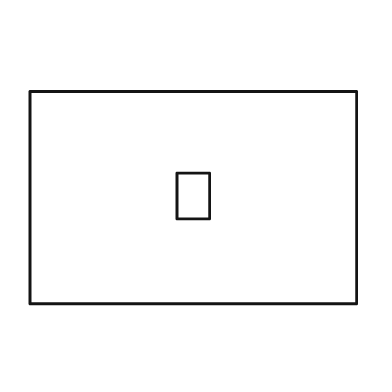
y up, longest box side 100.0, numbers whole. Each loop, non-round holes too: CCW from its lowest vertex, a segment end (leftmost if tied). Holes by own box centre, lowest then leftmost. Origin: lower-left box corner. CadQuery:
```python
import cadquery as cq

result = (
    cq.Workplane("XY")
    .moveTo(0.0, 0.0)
    .lineTo(100.0, 0.0)
    .lineTo(100.0, 65.0)
    .lineTo(0.0, 65.0)
    .close()
    .moveTo(45.0, 26.0)
    .lineTo(55.0, 26.0)
    .lineTo(55.0, 40.0)
    .lineTo(45.0, 40.0)
    .close()
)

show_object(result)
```